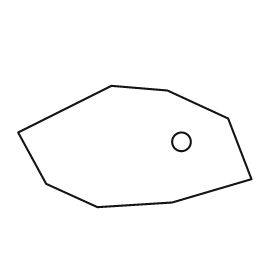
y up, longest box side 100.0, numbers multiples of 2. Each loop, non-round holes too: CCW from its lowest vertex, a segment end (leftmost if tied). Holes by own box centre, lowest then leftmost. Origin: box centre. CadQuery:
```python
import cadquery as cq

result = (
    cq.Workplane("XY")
    .moveTo(-16.0, -26.0)
    .lineTo(16.0, -24.0)
    .lineTo(50.0, -14.0)
    .lineTo(40.0, 12.0)
    .lineTo(14.0, 24.0)
    .lineTo(-10.0, 26.0)
    .lineTo(-50.0, 6.0)
    .lineTo(-38.0, -16.0)
    .close()
    .moveTo(20.0, 2.0)
    .circle(4.0)
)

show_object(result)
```